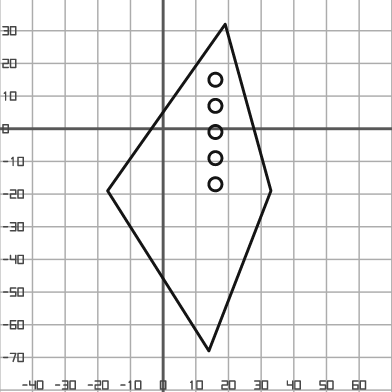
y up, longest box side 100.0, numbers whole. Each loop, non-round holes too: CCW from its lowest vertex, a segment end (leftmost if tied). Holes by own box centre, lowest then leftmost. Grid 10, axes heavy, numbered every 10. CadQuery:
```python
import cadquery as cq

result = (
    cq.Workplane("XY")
    .moveTo(14.0, -68.0)
    .lineTo(33.0, -19.0)
    .lineTo(19.0, 32.0)
    .lineTo(-17.0, -19.0)
    .close()
    .moveTo(16.0, -17.0)
    .circle(2.0)
    .moveTo(16.0, -9.0)
    .circle(2.0)
    .moveTo(16.0, -1.0)
    .circle(2.0)
    .moveTo(16.0, 7.0)
    .circle(2.0)
    .moveTo(16.0, 15.0)
    .circle(2.0)
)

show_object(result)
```